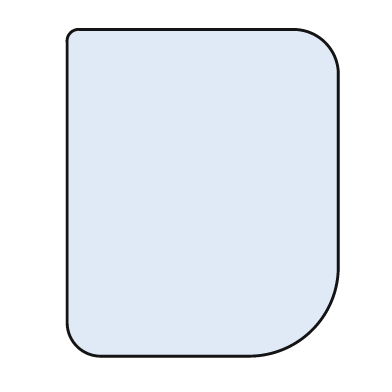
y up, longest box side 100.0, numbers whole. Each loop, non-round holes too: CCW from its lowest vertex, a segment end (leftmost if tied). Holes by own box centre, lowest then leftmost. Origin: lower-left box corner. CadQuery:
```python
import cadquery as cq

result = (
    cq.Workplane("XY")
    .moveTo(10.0, 0.0)
    .lineTo(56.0, 0.0)
    .threePointArc((75.0, 8.0), (83.0, 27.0))
    .lineTo(83.0, 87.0)
    .threePointArc((79.0, 96.0), (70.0, 100.0))
    .lineTo(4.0, 100.0)
    .threePointArc((1.0, 99.0), (0.0, 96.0))
    .lineTo(0.0, 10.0)
    .threePointArc((3.0, 3.0), (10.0, 0.0))
    .close()
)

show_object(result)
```